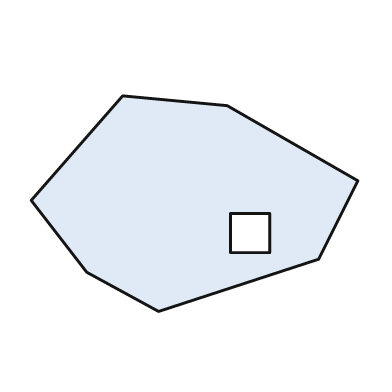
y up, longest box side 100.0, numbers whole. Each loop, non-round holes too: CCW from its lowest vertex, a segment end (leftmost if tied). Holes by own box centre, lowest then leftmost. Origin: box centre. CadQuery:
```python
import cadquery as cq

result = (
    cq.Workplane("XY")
    .moveTo(-11.0, -33.0)
    .lineTo(38.0, -17.0)
    .lineTo(50.0, 7.0)
    .lineTo(10.0, 30.0)
    .lineTo(-22.0, 33.0)
    .lineTo(-50.0, 1.0)
    .lineTo(-33.0, -21.0)
    .close()
    .moveTo(11.0, -15.0)
    .lineTo(23.0, -15.0)
    .lineTo(23.0, -3.0)
    .lineTo(11.0, -3.0)
    .close()
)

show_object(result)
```